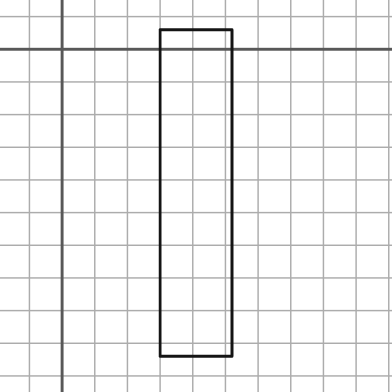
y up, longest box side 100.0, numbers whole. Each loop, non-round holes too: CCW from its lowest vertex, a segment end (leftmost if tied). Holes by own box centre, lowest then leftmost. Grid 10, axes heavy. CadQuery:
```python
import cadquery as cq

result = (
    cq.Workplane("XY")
    .moveTo(30.0, -94.0)
    .lineTo(52.0, -94.0)
    .lineTo(52.0, 6.0)
    .lineTo(30.0, 6.0)
    .close()
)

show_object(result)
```